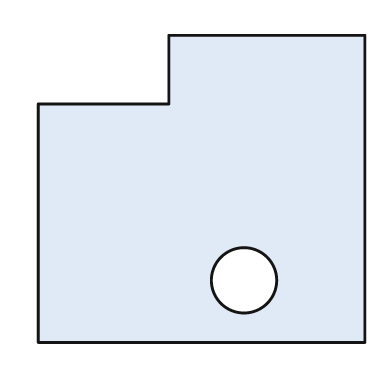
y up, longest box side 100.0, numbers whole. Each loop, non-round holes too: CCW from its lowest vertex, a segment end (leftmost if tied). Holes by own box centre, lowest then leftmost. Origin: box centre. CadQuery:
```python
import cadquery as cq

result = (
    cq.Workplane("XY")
    .moveTo(-50.0, -47.0)
    .lineTo(50.0, -47.0)
    .lineTo(50.0, 47.0)
    .lineTo(-10.0, 47.0)
    .lineTo(-10.0, 26.0)
    .lineTo(-50.0, 26.0)
    .close()
    .moveTo(13.0, -28.0)
    .circle(10.0)
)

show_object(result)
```